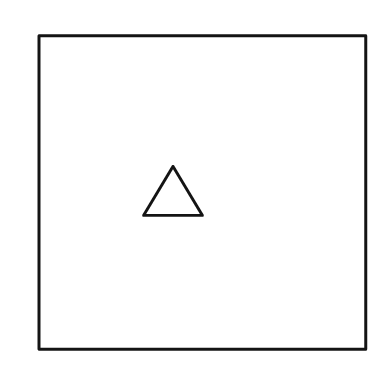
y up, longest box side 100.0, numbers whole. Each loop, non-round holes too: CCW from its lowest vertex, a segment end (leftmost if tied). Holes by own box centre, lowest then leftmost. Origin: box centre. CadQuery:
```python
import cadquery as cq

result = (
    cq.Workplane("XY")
    .moveTo(-50.0, -48.0)
    .lineTo(50.0, -48.0)
    .lineTo(50.0, 48.0)
    .lineTo(-50.0, 48.0)
    .close()
    .moveTo(-18.0, -7.0)
    .lineTo(0.0, -7.0)
    .lineTo(-9.0, 8.0)
    .close()
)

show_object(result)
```